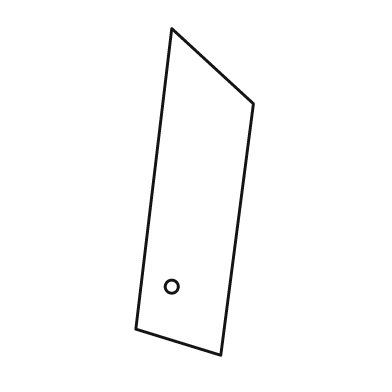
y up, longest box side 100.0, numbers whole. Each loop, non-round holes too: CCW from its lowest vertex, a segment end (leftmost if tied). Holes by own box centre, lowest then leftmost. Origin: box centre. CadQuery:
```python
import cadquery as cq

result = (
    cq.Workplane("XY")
    .moveTo(8.0, -50.0)
    .lineTo(18.0, 27.0)
    .lineTo(-7.0, 50.0)
    .lineTo(-18.0, -42.0)
    .close()
    .moveTo(-7.0, -29.0)
    .circle(2.0)
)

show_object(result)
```